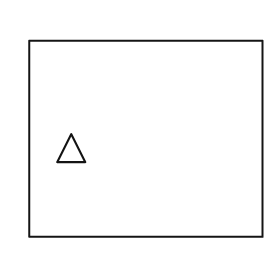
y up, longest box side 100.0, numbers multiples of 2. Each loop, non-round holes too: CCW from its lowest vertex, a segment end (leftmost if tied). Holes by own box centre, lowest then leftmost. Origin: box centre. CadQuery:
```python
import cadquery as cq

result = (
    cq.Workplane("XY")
    .moveTo(-50.0, -42.0)
    .lineTo(50.0, -42.0)
    .lineTo(50.0, 42.0)
    .lineTo(-50.0, 42.0)
    .close()
    .moveTo(-38.0, -10.0)
    .lineTo(-26.0, -10.0)
    .lineTo(-32.0, 2.0)
    .close()
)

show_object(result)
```